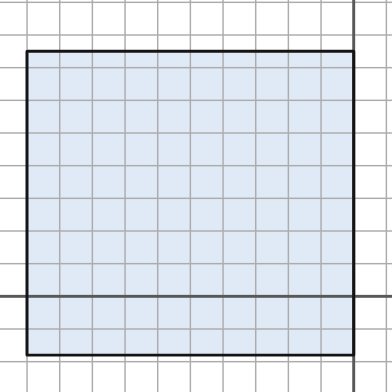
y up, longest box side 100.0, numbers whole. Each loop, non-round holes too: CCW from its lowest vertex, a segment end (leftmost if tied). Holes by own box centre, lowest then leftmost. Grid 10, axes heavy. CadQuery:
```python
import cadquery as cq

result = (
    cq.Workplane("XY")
    .moveTo(-100.0, -18.0)
    .lineTo(0.0, -18.0)
    .lineTo(0.0, 75.0)
    .lineTo(-100.0, 75.0)
    .close()
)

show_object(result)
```